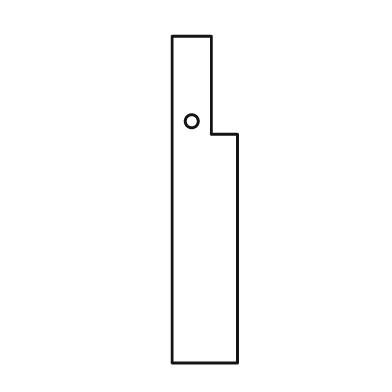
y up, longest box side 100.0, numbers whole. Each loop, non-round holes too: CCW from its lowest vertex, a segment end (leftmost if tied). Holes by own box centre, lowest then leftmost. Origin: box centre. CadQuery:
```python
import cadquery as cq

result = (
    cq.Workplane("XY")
    .moveTo(-10.0, -50.0)
    .lineTo(10.0, -50.0)
    .lineTo(10.0, 20.0)
    .lineTo(2.0, 20.0)
    .lineTo(2.0, 50.0)
    .lineTo(-10.0, 50.0)
    .close()
    .moveTo(-4.0, 24.0)
    .circle(2.0)
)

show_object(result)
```